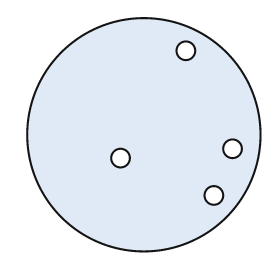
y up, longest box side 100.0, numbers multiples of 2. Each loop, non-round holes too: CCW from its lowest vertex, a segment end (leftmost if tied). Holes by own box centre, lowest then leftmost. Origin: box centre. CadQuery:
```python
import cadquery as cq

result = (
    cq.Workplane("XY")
    .moveTo(0.0, 0.0)
    .circle(50.0)
    .moveTo(30.0, -26.0)
    .circle(4.0)
    .moveTo(-10.0, -10.0)
    .circle(4.0)
    .moveTo(38.0, -6.0)
    .circle(4.0)
    .moveTo(18.0, 36.0)
    .circle(4.0)
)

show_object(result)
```